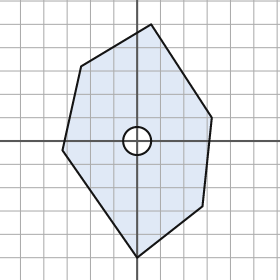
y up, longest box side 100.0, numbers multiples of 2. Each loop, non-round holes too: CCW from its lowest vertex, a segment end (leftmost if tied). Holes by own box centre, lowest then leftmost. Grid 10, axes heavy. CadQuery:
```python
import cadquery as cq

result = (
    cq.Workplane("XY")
    .moveTo(0.0, -50.0)
    .lineTo(28.0, -28.0)
    .lineTo(32.0, 10.0)
    .lineTo(6.0, 50.0)
    .lineTo(-24.0, 32.0)
    .lineTo(-32.0, -4.0)
    .close()
    .moveTo(0.0, 0.0)
    .circle(6.0)
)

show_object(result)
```